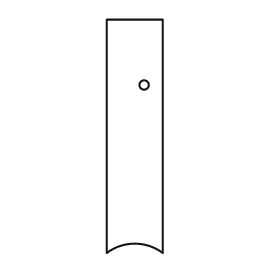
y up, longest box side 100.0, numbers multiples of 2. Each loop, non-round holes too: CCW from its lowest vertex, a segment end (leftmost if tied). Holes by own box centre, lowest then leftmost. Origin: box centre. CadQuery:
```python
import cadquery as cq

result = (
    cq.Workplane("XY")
    .moveTo(-12.0, -50.0)
    .threePointArc((0.0, -46.0), (12.0, -50.0))
    .lineTo(12.0, 50.0)
    .lineTo(-12.0, 50.0)
    .close()
    .moveTo(4.0, 22.0)
    .circle(2.0)
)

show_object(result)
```